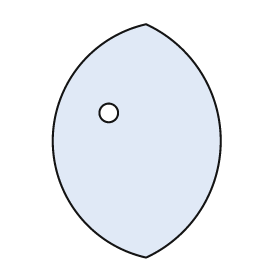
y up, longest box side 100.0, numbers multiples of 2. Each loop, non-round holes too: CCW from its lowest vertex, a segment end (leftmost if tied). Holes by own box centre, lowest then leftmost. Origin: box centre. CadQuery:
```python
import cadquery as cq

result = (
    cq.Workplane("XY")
    .moveTo(4.0, -50.0)
    .threePointArc((36.0, 0.0), (4.0, 50.0))
    .threePointArc((-36.0, 0.0), (4.0, -50.0))
    .close()
    .moveTo(-12.0, 12.0)
    .circle(4.0)
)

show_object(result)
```